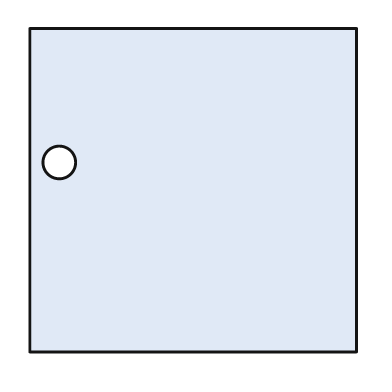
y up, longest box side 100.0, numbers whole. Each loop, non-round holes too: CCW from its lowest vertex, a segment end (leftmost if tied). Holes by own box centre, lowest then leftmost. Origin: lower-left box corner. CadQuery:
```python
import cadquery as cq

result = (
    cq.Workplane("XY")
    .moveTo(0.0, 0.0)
    .lineTo(100.0, 0.0)
    .lineTo(100.0, 99.0)
    .lineTo(0.0, 99.0)
    .close()
    .moveTo(9.0, 58.0)
    .circle(5.0)
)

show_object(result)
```